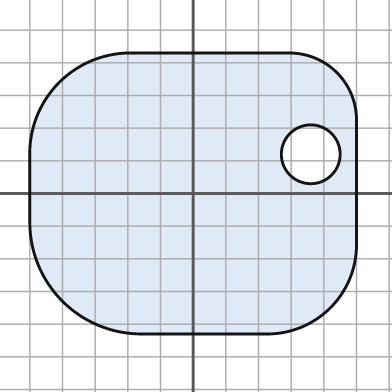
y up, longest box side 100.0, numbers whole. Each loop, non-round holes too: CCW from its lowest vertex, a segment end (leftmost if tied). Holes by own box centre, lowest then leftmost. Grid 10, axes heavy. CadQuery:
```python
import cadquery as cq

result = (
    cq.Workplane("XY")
    .moveTo(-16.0, -43.0)
    .lineTo(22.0, -43.0)
    .threePointArc((42.0, -35.0), (50.0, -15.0))
    .lineTo(50.0, 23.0)
    .threePointArc((44.0, 37.0), (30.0, 43.0))
    .lineTo(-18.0, 43.0)
    .threePointArc((-41.0, 34.0), (-50.0, 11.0))
    .lineTo(-50.0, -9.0)
    .threePointArc((-40.0, -33.0), (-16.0, -43.0))
    .close()
    .moveTo(36.0, 12.0)
    .circle(9.0)
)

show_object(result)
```